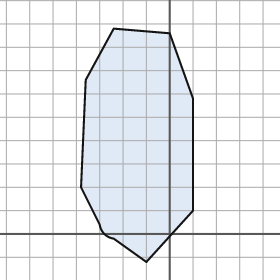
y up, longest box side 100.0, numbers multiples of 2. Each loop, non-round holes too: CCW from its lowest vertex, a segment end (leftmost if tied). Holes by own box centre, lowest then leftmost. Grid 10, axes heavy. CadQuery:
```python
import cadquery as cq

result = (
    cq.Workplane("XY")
    .moveTo(-10.0, -12.0)
    .lineTo(10.0, 10.0)
    .lineTo(10.0, 58.0)
    .lineTo(0.0, 86.0)
    .lineTo(-24.0, 88.0)
    .lineTo(-36.0, 66.0)
    .lineTo(-38.0, 20.0)
    .lineTo(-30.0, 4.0)
    .threePointArc((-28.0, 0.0), (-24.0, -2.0))
    .close()
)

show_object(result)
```